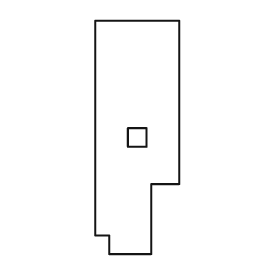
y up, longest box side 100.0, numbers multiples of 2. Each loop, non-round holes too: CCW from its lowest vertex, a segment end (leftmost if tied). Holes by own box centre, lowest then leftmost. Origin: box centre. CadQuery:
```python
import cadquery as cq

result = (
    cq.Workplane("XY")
    .moveTo(-12.0, -50.0)
    .lineTo(6.0, -50.0)
    .lineTo(6.0, -20.0)
    .lineTo(18.0, -20.0)
    .lineTo(18.0, 50.0)
    .lineTo(-18.0, 50.0)
    .lineTo(-18.0, -42.0)
    .lineTo(-12.0, -42.0)
    .close()
    .moveTo(-4.0, -4.0)
    .lineTo(4.0, -4.0)
    .lineTo(4.0, 4.0)
    .lineTo(-4.0, 4.0)
    .close()
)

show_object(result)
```